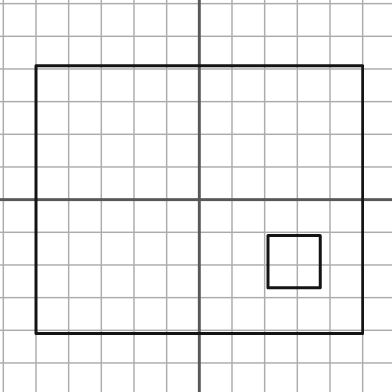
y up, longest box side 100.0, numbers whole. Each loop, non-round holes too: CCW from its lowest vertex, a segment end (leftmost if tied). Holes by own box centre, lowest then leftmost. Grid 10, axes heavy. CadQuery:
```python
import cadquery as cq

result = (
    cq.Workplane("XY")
    .moveTo(-50.0, -41.0)
    .lineTo(50.0, -41.0)
    .lineTo(50.0, 41.0)
    .lineTo(-50.0, 41.0)
    .close()
    .moveTo(21.0, -27.0)
    .lineTo(37.0, -27.0)
    .lineTo(37.0, -11.0)
    .lineTo(21.0, -11.0)
    .close()
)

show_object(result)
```